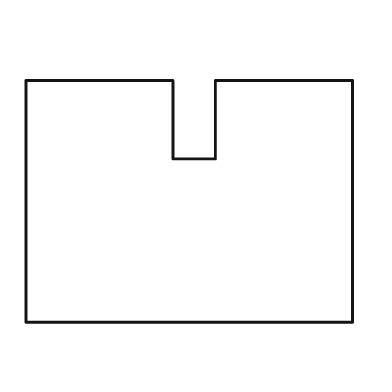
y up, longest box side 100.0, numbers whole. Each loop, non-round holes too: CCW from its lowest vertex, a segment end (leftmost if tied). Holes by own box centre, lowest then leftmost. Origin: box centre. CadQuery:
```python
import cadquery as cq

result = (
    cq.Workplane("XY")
    .moveTo(-50.0, -37.0)
    .lineTo(50.0, -37.0)
    .lineTo(50.0, 37.0)
    .lineTo(8.0, 37.0)
    .lineTo(8.0, 13.0)
    .lineTo(-5.0, 13.0)
    .lineTo(-5.0, 37.0)
    .lineTo(-50.0, 37.0)
    .close()
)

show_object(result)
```